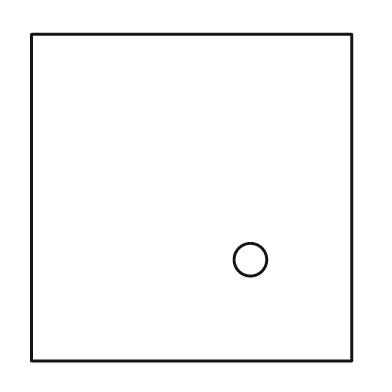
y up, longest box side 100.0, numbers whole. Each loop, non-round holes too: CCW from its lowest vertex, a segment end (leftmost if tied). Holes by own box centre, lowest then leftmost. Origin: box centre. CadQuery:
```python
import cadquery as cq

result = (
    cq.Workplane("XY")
    .moveTo(-49.0, -50.0)
    .lineTo(49.0, -50.0)
    .lineTo(49.0, 50.0)
    .lineTo(-49.0, 50.0)
    .close()
    .moveTo(18.0, -19.0)
    .circle(5.0)
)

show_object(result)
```